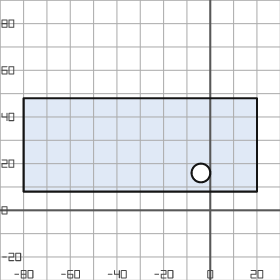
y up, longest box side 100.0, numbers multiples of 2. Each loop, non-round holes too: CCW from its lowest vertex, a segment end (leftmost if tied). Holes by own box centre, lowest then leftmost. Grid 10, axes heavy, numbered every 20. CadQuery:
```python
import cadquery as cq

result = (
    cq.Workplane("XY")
    .moveTo(-80.0, 8.0)
    .lineTo(20.0, 8.0)
    .lineTo(20.0, 48.0)
    .lineTo(-80.0, 48.0)
    .close()
    .moveTo(-4.0, 16.0)
    .circle(4.0)
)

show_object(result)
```